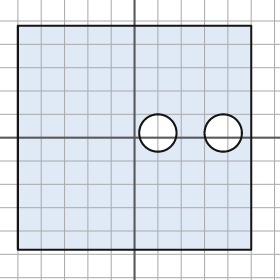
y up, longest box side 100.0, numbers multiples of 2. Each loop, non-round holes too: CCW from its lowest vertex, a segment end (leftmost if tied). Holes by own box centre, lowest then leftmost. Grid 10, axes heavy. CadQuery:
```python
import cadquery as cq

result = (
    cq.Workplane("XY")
    .moveTo(-50.0, -48.0)
    .lineTo(50.0, -48.0)
    .lineTo(50.0, 48.0)
    .lineTo(-50.0, 48.0)
    .close()
    .moveTo(10.0, 2.0)
    .circle(8.0)
    .moveTo(38.0, 2.0)
    .circle(8.0)
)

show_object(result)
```